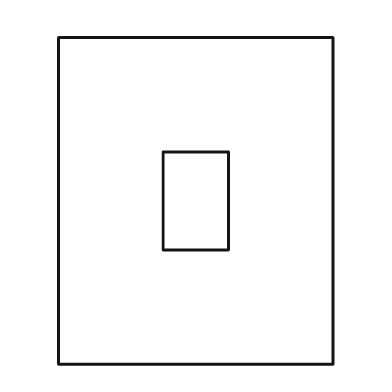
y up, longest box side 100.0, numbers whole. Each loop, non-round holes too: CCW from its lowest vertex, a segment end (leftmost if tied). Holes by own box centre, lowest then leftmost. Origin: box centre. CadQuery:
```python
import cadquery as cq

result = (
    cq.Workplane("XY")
    .moveTo(-42.0, -50.0)
    .lineTo(42.0, -50.0)
    .lineTo(42.0, 50.0)
    .lineTo(-42.0, 50.0)
    .close()
    .moveTo(-10.0, -15.0)
    .lineTo(10.0, -15.0)
    .lineTo(10.0, 15.0)
    .lineTo(-10.0, 15.0)
    .close()
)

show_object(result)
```